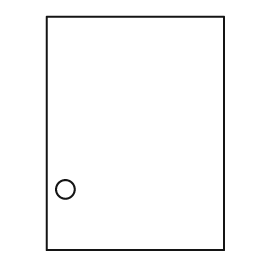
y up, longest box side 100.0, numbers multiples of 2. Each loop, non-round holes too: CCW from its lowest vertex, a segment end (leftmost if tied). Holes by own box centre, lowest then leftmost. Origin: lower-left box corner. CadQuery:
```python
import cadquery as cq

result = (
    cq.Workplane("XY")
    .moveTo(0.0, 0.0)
    .lineTo(76.0, 0.0)
    .lineTo(76.0, 100.0)
    .lineTo(0.0, 100.0)
    .close()
    .moveTo(8.0, 26.0)
    .circle(4.0)
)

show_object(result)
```